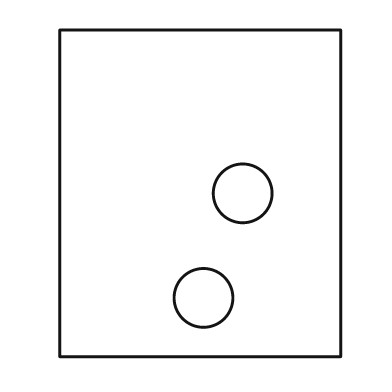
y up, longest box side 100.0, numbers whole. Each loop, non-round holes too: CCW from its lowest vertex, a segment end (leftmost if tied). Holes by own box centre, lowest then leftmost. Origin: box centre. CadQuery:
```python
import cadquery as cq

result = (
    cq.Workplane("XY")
    .moveTo(-43.0, -50.0)
    .lineTo(43.0, -50.0)
    .lineTo(43.0, 50.0)
    .lineTo(-43.0, 50.0)
    .close()
    .moveTo(1.0, -32.0)
    .circle(9.0)
    .moveTo(13.0, 0.0)
    .circle(9.0)
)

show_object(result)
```